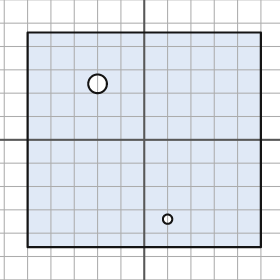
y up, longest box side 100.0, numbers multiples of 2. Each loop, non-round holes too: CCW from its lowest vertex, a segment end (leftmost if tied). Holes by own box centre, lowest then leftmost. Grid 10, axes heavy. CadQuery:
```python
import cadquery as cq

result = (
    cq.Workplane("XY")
    .moveTo(-50.0, -46.0)
    .lineTo(50.0, -46.0)
    .lineTo(50.0, 46.0)
    .lineTo(-50.0, 46.0)
    .close()
    .moveTo(10.0, -34.0)
    .circle(2.0)
    .moveTo(-20.0, 24.0)
    .circle(4.0)
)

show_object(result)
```